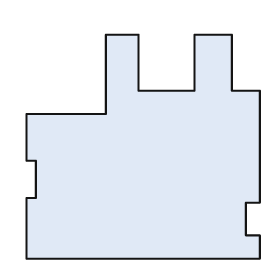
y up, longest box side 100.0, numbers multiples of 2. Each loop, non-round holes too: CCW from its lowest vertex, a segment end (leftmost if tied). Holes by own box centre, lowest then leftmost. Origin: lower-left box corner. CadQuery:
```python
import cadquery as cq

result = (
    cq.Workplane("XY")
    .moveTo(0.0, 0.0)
    .lineTo(100.0, 0.0)
    .lineTo(100.0, 10.0)
    .lineTo(94.0, 10.0)
    .lineTo(94.0, 24.0)
    .lineTo(100.0, 24.0)
    .lineTo(100.0, 72.0)
    .lineTo(88.0, 72.0)
    .lineTo(88.0, 96.0)
    .lineTo(72.0, 96.0)
    .lineTo(72.0, 72.0)
    .lineTo(48.0, 72.0)
    .lineTo(48.0, 96.0)
    .lineTo(34.0, 96.0)
    .lineTo(34.0, 62.0)
    .lineTo(0.0, 62.0)
    .lineTo(0.0, 42.0)
    .lineTo(4.0, 42.0)
    .lineTo(4.0, 26.0)
    .lineTo(0.0, 26.0)
    .close()
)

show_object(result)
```